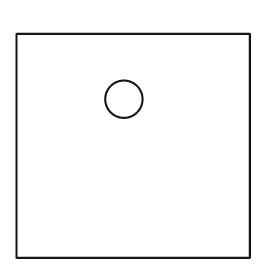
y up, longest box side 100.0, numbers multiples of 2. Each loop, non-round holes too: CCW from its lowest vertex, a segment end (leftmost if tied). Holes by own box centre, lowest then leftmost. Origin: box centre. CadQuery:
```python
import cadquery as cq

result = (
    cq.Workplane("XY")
    .moveTo(-50.0, -48.0)
    .lineTo(50.0, -48.0)
    .lineTo(50.0, 48.0)
    .lineTo(-50.0, 48.0)
    .close()
    .moveTo(-4.0, 20.0)
    .circle(8.0)
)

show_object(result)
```